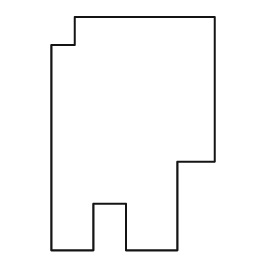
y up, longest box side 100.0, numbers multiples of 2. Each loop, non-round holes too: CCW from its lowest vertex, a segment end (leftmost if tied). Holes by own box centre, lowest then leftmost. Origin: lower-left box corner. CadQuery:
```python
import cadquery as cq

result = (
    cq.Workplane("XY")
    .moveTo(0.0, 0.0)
    .lineTo(18.0, 0.0)
    .lineTo(18.0, 20.0)
    .lineTo(32.0, 20.0)
    .lineTo(32.0, 0.0)
    .lineTo(54.0, 0.0)
    .lineTo(54.0, 38.0)
    .lineTo(70.0, 38.0)
    .lineTo(70.0, 100.0)
    .lineTo(10.0, 100.0)
    .lineTo(10.0, 88.0)
    .lineTo(0.0, 88.0)
    .close()
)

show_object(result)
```